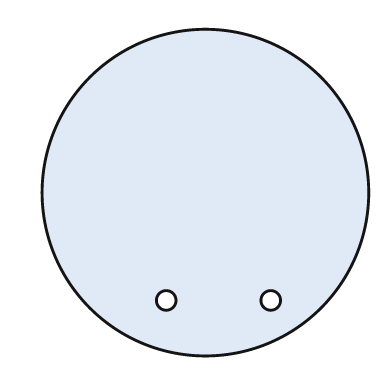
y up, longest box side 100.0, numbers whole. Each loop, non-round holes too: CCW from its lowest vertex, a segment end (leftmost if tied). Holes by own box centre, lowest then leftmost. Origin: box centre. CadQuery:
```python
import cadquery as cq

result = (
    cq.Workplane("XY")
    .moveTo(0.0, 0.0)
    .circle(50.0)
    .moveTo(-12.0, -33.0)
    .circle(3.0)
    .moveTo(20.0, -33.0)
    .circle(3.0)
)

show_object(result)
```